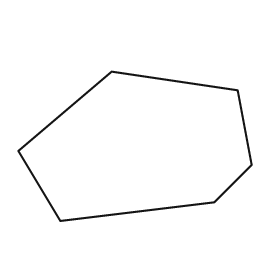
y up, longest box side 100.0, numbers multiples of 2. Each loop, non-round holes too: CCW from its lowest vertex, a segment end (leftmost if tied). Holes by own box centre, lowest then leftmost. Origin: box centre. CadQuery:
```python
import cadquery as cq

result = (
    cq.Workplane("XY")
    .moveTo(-32.0, -32.0)
    .lineTo(34.0, -24.0)
    .lineTo(50.0, -8.0)
    .lineTo(44.0, 24.0)
    .lineTo(-10.0, 32.0)
    .lineTo(-50.0, -2.0)
    .close()
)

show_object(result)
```